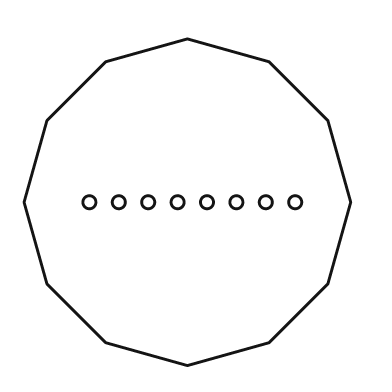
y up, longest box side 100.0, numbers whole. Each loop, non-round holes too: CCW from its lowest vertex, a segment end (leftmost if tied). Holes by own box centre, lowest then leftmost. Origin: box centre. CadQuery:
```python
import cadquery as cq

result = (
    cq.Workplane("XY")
    .moveTo(0.0, -50.0)
    .lineTo(25.0, -43.0)
    .lineTo(43.0, -25.0)
    .lineTo(50.0, 0.0)
    .lineTo(43.0, 25.0)
    .lineTo(25.0, 43.0)
    .lineTo(0.0, 50.0)
    .lineTo(-25.0, 43.0)
    .lineTo(-43.0, 25.0)
    .lineTo(-50.0, 0.0)
    .lineTo(-43.0, -25.0)
    .lineTo(-25.0, -43.0)
    .close()
    .moveTo(-30.0, 0.0)
    .circle(2.0)
    .moveTo(-21.0, 0.0)
    .circle(2.0)
    .moveTo(-12.0, 0.0)
    .circle(2.0)
    .moveTo(-3.0, 0.0)
    .circle(2.0)
    .moveTo(6.0, 0.0)
    .circle(2.0)
    .moveTo(15.0, 0.0)
    .circle(2.0)
    .moveTo(24.0, 0.0)
    .circle(2.0)
    .moveTo(33.0, 0.0)
    .circle(2.0)
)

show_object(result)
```